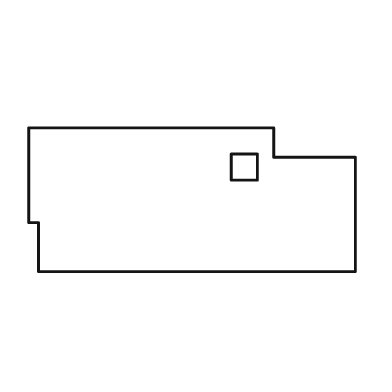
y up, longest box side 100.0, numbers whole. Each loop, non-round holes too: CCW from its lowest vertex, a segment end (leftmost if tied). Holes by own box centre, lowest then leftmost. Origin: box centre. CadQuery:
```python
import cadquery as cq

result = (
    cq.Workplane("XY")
    .moveTo(-47.0, -22.0)
    .lineTo(50.0, -22.0)
    .lineTo(50.0, 13.0)
    .lineTo(25.0, 13.0)
    .lineTo(25.0, 22.0)
    .lineTo(-50.0, 22.0)
    .lineTo(-50.0, -7.0)
    .lineTo(-47.0, -7.0)
    .close()
    .moveTo(12.0, 6.0)
    .lineTo(20.0, 6.0)
    .lineTo(20.0, 14.0)
    .lineTo(12.0, 14.0)
    .close()
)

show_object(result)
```